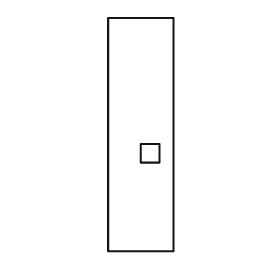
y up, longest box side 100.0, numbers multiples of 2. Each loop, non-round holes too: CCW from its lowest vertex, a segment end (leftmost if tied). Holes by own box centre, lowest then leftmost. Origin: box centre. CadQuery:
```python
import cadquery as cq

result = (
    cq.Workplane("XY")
    .moveTo(-14.0, -50.0)
    .lineTo(14.0, -50.0)
    .lineTo(14.0, 50.0)
    .lineTo(-14.0, 50.0)
    .close()
    .moveTo(0.0, -12.0)
    .lineTo(8.0, -12.0)
    .lineTo(8.0, -4.0)
    .lineTo(0.0, -4.0)
    .close()
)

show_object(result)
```